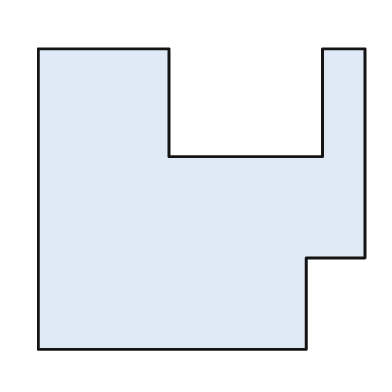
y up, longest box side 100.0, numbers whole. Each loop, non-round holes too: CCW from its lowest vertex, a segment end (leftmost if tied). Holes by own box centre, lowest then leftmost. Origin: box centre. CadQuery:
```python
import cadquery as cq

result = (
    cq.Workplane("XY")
    .moveTo(-50.0, -46.0)
    .lineTo(32.0, -46.0)
    .lineTo(32.0, -18.0)
    .lineTo(50.0, -18.0)
    .lineTo(50.0, 46.0)
    .lineTo(37.0, 46.0)
    .lineTo(37.0, 13.0)
    .lineTo(-10.0, 13.0)
    .lineTo(-10.0, 46.0)
    .lineTo(-50.0, 46.0)
    .close()
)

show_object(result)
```